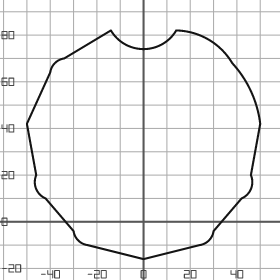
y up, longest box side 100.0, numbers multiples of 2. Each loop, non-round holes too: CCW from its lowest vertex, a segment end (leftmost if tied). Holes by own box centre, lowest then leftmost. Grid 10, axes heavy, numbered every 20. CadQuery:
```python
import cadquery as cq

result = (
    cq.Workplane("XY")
    .moveTo(0.0, -16.0)
    .lineTo(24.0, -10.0)
    .threePointArc((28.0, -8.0), (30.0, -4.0))
    .lineTo(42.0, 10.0)
    .threePointArc((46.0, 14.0), (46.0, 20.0))
    .lineTo(50.0, 42.0)
    .threePointArc((46.0, 56.0), (38.0, 68.0))
    .threePointArc((28.0, 78.0), (14.0, 82.0))
    .threePointArc((0.0, 74.0), (-14.0, 82.0))
    .lineTo(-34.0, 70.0)
    .threePointArc((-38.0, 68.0), (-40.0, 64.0))
    .lineTo(-50.0, 42.0)
    .lineTo(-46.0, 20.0)
    .threePointArc((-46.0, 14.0), (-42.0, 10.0))
    .lineTo(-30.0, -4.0)
    .threePointArc((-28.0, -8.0), (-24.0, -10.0))
    .close()
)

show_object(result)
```